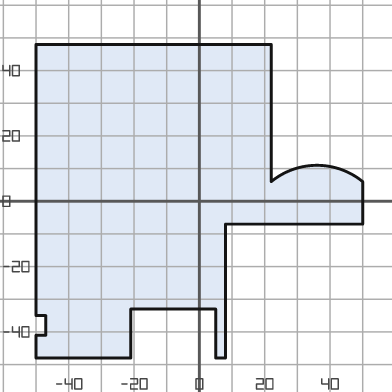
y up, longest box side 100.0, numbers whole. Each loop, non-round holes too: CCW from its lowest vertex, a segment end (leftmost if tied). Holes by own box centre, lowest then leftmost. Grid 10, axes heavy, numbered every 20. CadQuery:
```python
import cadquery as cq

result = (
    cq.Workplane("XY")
    .moveTo(-50.0, -48.0)
    .lineTo(-21.0, -48.0)
    .lineTo(-21.0, -33.0)
    .lineTo(5.0, -33.0)
    .lineTo(5.0, -48.0)
    .lineTo(8.0, -48.0)
    .lineTo(8.0, -7.0)
    .lineTo(50.0, -7.0)
    .lineTo(50.0, 6.0)
    .threePointArc((36.0, 11.0), (22.0, 6.0))
    .lineTo(22.0, 48.0)
    .lineTo(-50.0, 48.0)
    .lineTo(-50.0, -35.0)
    .lineTo(-47.0, -35.0)
    .lineTo(-47.0, -41.0)
    .lineTo(-50.0, -41.0)
    .close()
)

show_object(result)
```